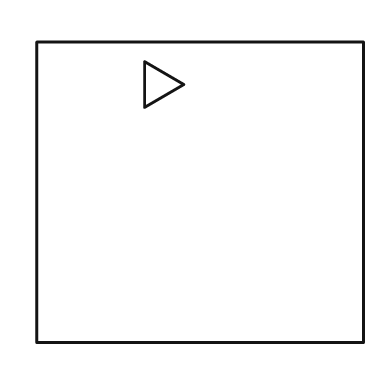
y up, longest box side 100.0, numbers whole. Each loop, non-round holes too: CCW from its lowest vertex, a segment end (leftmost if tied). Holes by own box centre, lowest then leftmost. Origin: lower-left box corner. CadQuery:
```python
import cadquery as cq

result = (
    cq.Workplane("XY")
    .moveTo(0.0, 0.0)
    .lineTo(100.0, 0.0)
    .lineTo(100.0, 92.0)
    .lineTo(0.0, 92.0)
    .close()
    .moveTo(33.0, 72.0)
    .lineTo(45.0, 79.0)
    .lineTo(33.0, 86.0)
    .close()
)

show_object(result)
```